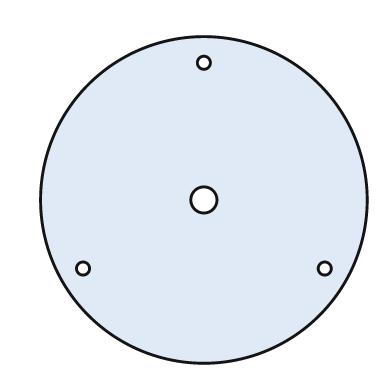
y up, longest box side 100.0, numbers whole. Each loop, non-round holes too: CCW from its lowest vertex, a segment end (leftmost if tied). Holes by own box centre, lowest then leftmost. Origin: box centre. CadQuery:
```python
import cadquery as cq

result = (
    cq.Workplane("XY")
    .moveTo(0.0, 0.0)
    .circle(50.0)
    .moveTo(-37.0, -21.0)
    .circle(2.0)
    .moveTo(37.0, -21.0)
    .circle(2.0)
    .moveTo(0.0, 0.0)
    .circle(4.0)
    .moveTo(0.0, 42.0)
    .circle(2.0)
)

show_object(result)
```